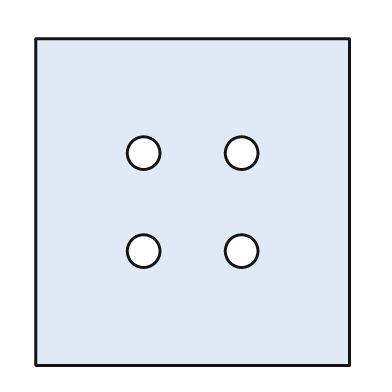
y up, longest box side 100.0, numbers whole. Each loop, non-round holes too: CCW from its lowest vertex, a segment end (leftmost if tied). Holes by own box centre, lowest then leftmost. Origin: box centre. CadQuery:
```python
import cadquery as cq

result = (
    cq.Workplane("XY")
    .moveTo(-48.0, -50.0)
    .lineTo(48.0, -50.0)
    .lineTo(48.0, 50.0)
    .lineTo(-48.0, 50.0)
    .close()
    .moveTo(-15.0, -15.0)
    .circle(5.0)
    .moveTo(15.0, -15.0)
    .circle(5.0)
    .moveTo(-15.0, 15.0)
    .circle(5.0)
    .moveTo(15.0, 15.0)
    .circle(5.0)
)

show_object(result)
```